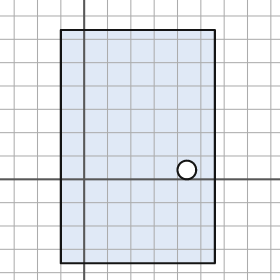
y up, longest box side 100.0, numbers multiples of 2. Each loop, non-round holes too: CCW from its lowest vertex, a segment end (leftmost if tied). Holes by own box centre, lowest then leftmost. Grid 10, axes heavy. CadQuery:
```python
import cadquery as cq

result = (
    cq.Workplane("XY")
    .moveTo(-10.0, -36.0)
    .lineTo(56.0, -36.0)
    .lineTo(56.0, 64.0)
    .lineTo(-10.0, 64.0)
    .close()
    .moveTo(44.0, 4.0)
    .circle(4.0)
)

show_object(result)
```